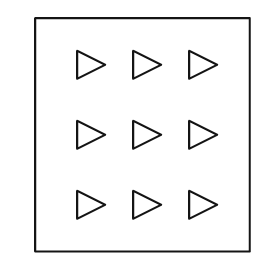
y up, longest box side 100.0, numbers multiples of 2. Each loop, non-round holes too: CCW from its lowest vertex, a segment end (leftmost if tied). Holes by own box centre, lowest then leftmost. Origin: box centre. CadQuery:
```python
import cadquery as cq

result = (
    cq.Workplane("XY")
    .moveTo(-46.0, -50.0)
    .lineTo(46.0, -50.0)
    .lineTo(46.0, 50.0)
    .lineTo(-46.0, 50.0)
    .close()
    .moveTo(-28.0, -36.0)
    .lineTo(-16.0, -30.0)
    .lineTo(-28.0, -24.0)
    .close()
    .moveTo(-4.0, -36.0)
    .lineTo(8.0, -30.0)
    .lineTo(-4.0, -24.0)
    .close()
    .moveTo(20.0, -36.0)
    .lineTo(32.0, -30.0)
    .lineTo(20.0, -24.0)
    .close()
    .moveTo(-28.0, -6.0)
    .lineTo(-16.0, 0.0)
    .lineTo(-28.0, 6.0)
    .close()
    .moveTo(-4.0, -6.0)
    .lineTo(8.0, 0.0)
    .lineTo(-4.0, 6.0)
    .close()
    .moveTo(20.0, -6.0)
    .lineTo(32.0, 0.0)
    .lineTo(20.0, 6.0)
    .close()
    .moveTo(-28.0, 24.0)
    .lineTo(-16.0, 30.0)
    .lineTo(-28.0, 36.0)
    .close()
    .moveTo(-4.0, 24.0)
    .lineTo(8.0, 30.0)
    .lineTo(-4.0, 36.0)
    .close()
    .moveTo(20.0, 24.0)
    .lineTo(32.0, 30.0)
    .lineTo(20.0, 36.0)
    .close()
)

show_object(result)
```